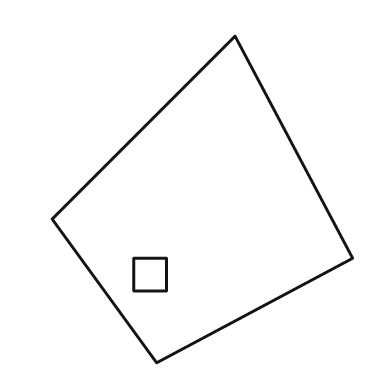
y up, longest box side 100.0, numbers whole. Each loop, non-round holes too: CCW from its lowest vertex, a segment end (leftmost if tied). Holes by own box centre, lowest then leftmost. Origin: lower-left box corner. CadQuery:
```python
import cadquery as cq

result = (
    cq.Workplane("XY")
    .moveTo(32.0, 0.0)
    .lineTo(92.0, 32.0)
    .lineTo(56.0, 100.0)
    .lineTo(0.0, 44.0)
    .close()
    .moveTo(25.0, 22.0)
    .lineTo(35.0, 22.0)
    .lineTo(35.0, 32.0)
    .lineTo(25.0, 32.0)
    .close()
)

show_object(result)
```